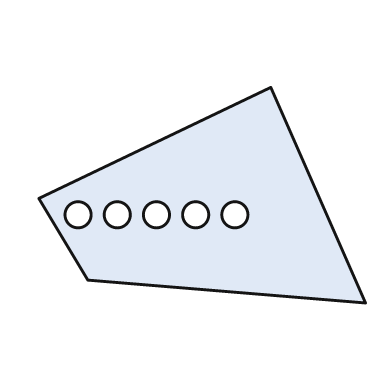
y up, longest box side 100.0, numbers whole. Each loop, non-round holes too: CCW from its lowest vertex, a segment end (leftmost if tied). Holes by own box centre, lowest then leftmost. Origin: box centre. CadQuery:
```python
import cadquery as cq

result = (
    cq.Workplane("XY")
    .moveTo(50.0, -33.0)
    .lineTo(21.0, 33.0)
    .lineTo(-50.0, -1.0)
    .lineTo(-35.0, -26.0)
    .close()
    .moveTo(-38.0, -6.0)
    .circle(4.0)
    .moveTo(-26.0, -6.0)
    .circle(4.0)
    .moveTo(-14.0, -6.0)
    .circle(4.0)
    .moveTo(-2.0, -6.0)
    .circle(4.0)
    .moveTo(10.0, -6.0)
    .circle(4.0)
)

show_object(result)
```